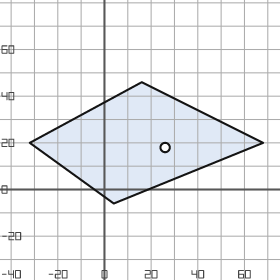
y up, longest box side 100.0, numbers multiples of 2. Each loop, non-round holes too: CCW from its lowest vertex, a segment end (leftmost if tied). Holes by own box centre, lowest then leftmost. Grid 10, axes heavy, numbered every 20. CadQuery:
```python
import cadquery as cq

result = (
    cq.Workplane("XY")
    .moveTo(4.0, -6.0)
    .lineTo(68.0, 20.0)
    .lineTo(16.0, 46.0)
    .lineTo(-32.0, 20.0)
    .close()
    .moveTo(26.0, 18.0)
    .circle(2.0)
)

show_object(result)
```